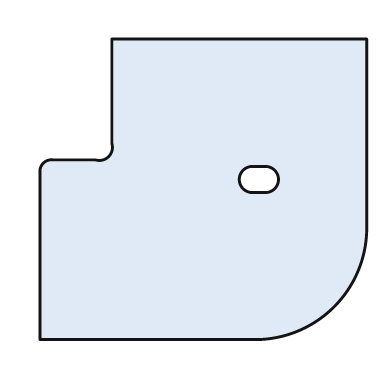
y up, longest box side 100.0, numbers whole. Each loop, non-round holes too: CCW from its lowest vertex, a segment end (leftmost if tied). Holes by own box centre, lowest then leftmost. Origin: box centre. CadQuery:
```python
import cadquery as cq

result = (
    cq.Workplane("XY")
    .moveTo(-50.0, -46.0)
    .lineTo(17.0, -46.0)
    .threePointArc((40.0, -36.0), (50.0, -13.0))
    .lineTo(50.0, 46.0)
    .lineTo(-28.0, 46.0)
    .lineTo(-28.0, 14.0)
    .threePointArc((-29.0, 10.0), (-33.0, 9.0))
    .lineTo(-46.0, 9.0)
    .threePointArc((-49.0, 8.0), (-50.0, 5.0))
    .close()
    .moveTo(15.0, -1.0)
    .lineTo(19.0, -1.0)
    .threePointArc((23.0, 3.0), (19.0, 7.0))
    .lineTo(15.0, 7.0)
    .threePointArc((11.0, 3.0), (15.0, -1.0))
    .close()
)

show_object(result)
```